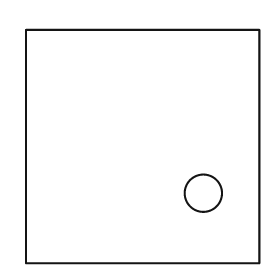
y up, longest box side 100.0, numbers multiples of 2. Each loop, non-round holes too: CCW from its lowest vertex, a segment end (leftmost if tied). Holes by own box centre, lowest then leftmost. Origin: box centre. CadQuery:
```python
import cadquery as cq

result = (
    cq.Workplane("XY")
    .moveTo(-50.0, -50.0)
    .lineTo(50.0, -50.0)
    .lineTo(50.0, 50.0)
    .lineTo(-50.0, 50.0)
    .close()
    .moveTo(26.0, -20.0)
    .circle(8.0)
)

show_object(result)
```